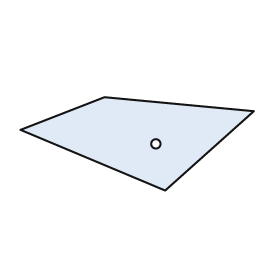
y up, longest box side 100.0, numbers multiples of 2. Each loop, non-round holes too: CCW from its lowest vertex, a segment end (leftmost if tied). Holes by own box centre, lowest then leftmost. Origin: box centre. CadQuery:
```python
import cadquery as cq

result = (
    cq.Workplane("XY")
    .moveTo(12.0, -20.0)
    .lineTo(50.0, 14.0)
    .lineTo(-14.0, 20.0)
    .lineTo(-50.0, 6.0)
    .close()
    .moveTo(8.0, 0.0)
    .circle(2.0)
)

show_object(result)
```